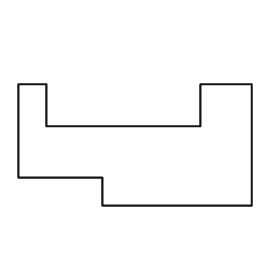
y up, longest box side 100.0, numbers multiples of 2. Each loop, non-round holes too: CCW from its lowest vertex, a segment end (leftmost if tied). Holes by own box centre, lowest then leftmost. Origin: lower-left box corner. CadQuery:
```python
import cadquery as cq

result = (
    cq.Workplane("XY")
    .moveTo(36.0, 0.0)
    .lineTo(100.0, 0.0)
    .lineTo(100.0, 52.0)
    .lineTo(78.0, 52.0)
    .lineTo(78.0, 34.0)
    .lineTo(12.0, 34.0)
    .lineTo(12.0, 52.0)
    .lineTo(0.0, 52.0)
    .lineTo(0.0, 12.0)
    .lineTo(36.0, 12.0)
    .close()
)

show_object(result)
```